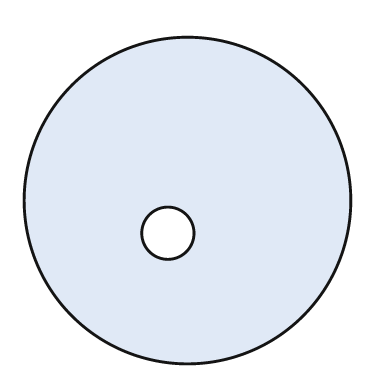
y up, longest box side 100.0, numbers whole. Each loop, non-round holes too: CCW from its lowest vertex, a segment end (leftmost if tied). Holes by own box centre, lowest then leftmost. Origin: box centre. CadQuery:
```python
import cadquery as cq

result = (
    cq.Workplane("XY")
    .moveTo(0.0, 0.0)
    .circle(50.0)
    .moveTo(-6.0, -10.0)
    .circle(8.0)
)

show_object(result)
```